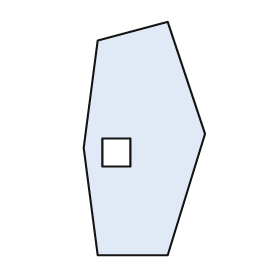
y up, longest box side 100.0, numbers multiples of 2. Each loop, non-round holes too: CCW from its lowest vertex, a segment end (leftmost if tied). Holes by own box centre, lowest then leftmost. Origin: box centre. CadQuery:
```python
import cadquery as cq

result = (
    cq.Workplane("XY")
    .moveTo(-20.0, -50.0)
    .lineTo(10.0, -50.0)
    .lineTo(26.0, 2.0)
    .lineTo(10.0, 50.0)
    .lineTo(-20.0, 42.0)
    .lineTo(-26.0, -4.0)
    .close()
    .moveTo(-18.0, -12.0)
    .lineTo(-6.0, -12.0)
    .lineTo(-6.0, 0.0)
    .lineTo(-18.0, 0.0)
    .close()
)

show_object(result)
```